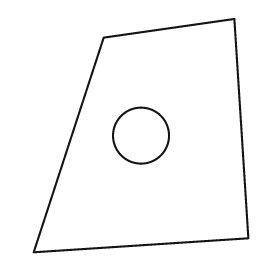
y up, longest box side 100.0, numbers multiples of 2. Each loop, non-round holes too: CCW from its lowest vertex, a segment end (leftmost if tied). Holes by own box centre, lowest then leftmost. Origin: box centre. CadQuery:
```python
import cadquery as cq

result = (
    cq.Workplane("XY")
    .moveTo(-46.0, -50.0)
    .lineTo(46.0, -44.0)
    .lineTo(40.0, 50.0)
    .lineTo(-16.0, 42.0)
    .close()
    .moveTo(0.0, 0.0)
    .circle(12.0)
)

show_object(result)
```